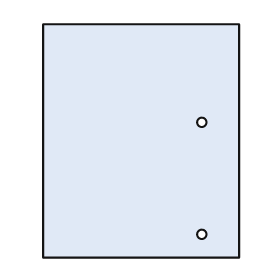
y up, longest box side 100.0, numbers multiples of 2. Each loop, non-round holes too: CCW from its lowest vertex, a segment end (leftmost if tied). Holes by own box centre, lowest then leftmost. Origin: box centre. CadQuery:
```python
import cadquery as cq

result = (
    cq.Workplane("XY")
    .moveTo(-42.0, -50.0)
    .lineTo(42.0, -50.0)
    .lineTo(42.0, 50.0)
    .lineTo(-42.0, 50.0)
    .close()
    .moveTo(26.0, -40.0)
    .circle(2.0)
    .moveTo(26.0, 8.0)
    .circle(2.0)
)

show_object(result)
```